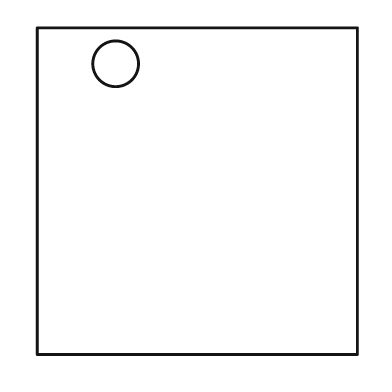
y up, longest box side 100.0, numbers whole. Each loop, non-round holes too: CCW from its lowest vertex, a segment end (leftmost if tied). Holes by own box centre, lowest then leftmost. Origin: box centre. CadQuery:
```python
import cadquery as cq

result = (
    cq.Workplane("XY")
    .moveTo(-49.0, -50.0)
    .lineTo(49.0, -50.0)
    .lineTo(49.0, 50.0)
    .lineTo(-49.0, 50.0)
    .close()
    .moveTo(-25.0, 39.0)
    .circle(7.0)
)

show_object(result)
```